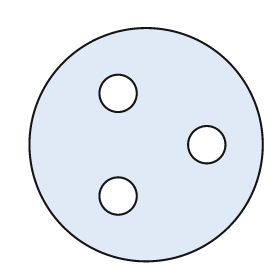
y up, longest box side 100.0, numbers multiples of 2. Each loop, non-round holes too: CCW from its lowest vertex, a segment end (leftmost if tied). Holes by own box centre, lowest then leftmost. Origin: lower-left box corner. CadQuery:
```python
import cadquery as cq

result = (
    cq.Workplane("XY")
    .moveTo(50.0, 50.0)
    .circle(50.0)
    .moveTo(38.0, 28.0)
    .circle(8.0)
    .moveTo(76.0, 50.0)
    .circle(8.0)
    .moveTo(38.0, 72.0)
    .circle(8.0)
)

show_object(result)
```